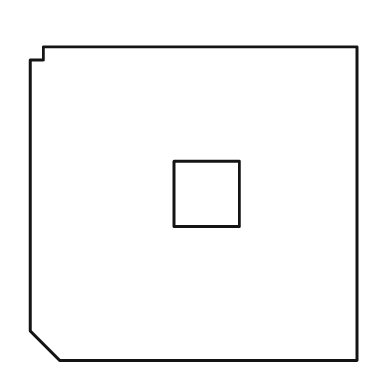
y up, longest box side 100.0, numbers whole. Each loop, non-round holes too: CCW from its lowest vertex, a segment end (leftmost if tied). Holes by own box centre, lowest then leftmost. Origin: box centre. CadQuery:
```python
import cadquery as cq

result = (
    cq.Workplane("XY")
    .moveTo(-41.0, -48.0)
    .lineTo(50.0, -48.0)
    .lineTo(50.0, 48.0)
    .lineTo(-46.0, 48.0)
    .lineTo(-46.0, 44.0)
    .lineTo(-50.0, 44.0)
    .lineTo(-50.0, -39.0)
    .close()
    .moveTo(-6.0, -7.0)
    .lineTo(14.0, -7.0)
    .lineTo(14.0, 13.0)
    .lineTo(-6.0, 13.0)
    .close()
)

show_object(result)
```